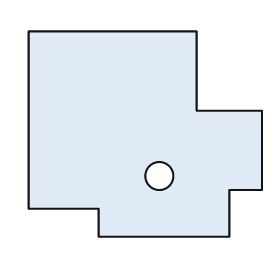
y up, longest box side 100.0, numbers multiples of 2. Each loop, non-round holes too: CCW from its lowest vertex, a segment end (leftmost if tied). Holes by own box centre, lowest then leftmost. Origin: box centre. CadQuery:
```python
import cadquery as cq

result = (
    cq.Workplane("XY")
    .moveTo(-20.0, -44.0)
    .lineTo(36.0, -44.0)
    .lineTo(36.0, -24.0)
    .lineTo(50.0, -24.0)
    .lineTo(50.0, 10.0)
    .lineTo(22.0, 10.0)
    .lineTo(22.0, 44.0)
    .lineTo(-50.0, 44.0)
    .lineTo(-50.0, -32.0)
    .lineTo(-20.0, -32.0)
    .close()
    .moveTo(6.0, -18.0)
    .circle(6.0)
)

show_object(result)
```